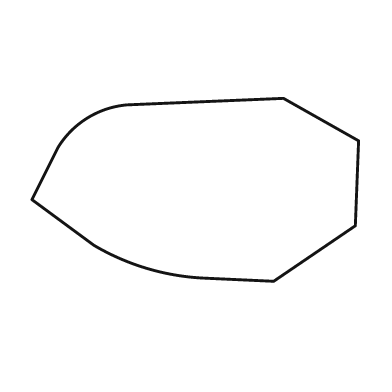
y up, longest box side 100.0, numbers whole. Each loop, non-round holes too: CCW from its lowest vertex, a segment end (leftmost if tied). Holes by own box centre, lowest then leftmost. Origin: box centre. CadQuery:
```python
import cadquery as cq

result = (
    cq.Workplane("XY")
    .moveTo(24.0, -28.0)
    .lineTo(49.0, -11.0)
    .lineTo(50.0, 15.0)
    .lineTo(27.0, 28.0)
    .lineTo(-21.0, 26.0)
    .threePointArc((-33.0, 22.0), (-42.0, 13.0))
    .lineTo(-50.0, -3.0)
    .lineTo(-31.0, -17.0)
    .threePointArc((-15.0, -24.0), (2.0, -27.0))
    .close()
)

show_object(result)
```